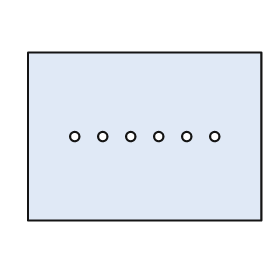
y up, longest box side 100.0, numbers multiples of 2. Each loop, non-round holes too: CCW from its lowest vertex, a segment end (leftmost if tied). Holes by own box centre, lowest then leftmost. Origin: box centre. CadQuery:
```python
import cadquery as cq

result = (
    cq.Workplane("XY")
    .moveTo(-50.0, -36.0)
    .lineTo(50.0, -36.0)
    .lineTo(50.0, 36.0)
    .lineTo(-50.0, 36.0)
    .close()
    .moveTo(-30.0, 0.0)
    .circle(2.0)
    .moveTo(-18.0, 0.0)
    .circle(2.0)
    .moveTo(-6.0, 0.0)
    .circle(2.0)
    .moveTo(6.0, 0.0)
    .circle(2.0)
    .moveTo(18.0, 0.0)
    .circle(2.0)
    .moveTo(30.0, 0.0)
    .circle(2.0)
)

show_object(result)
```